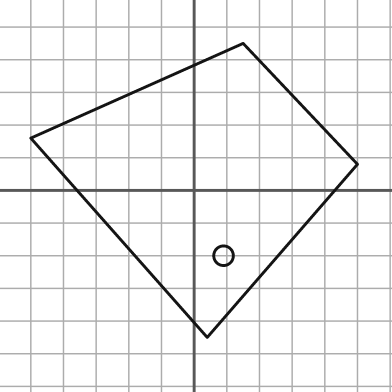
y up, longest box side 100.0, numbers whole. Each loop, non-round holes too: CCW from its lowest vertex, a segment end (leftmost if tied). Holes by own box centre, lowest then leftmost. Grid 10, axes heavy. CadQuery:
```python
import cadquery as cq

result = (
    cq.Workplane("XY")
    .moveTo(4.0, -45.0)
    .lineTo(50.0, 8.0)
    .lineTo(15.0, 45.0)
    .lineTo(-50.0, 16.0)
    .close()
    .moveTo(9.0, -20.0)
    .circle(3.0)
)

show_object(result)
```